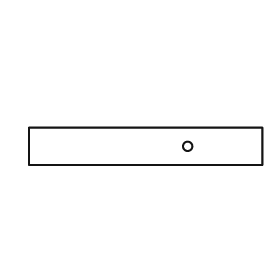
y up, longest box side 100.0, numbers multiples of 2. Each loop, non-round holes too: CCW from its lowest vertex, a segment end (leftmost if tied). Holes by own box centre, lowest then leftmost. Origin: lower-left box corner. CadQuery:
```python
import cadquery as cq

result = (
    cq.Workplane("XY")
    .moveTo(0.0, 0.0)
    .lineTo(100.0, 0.0)
    .lineTo(100.0, 16.0)
    .lineTo(0.0, 16.0)
    .close()
    .moveTo(68.0, 8.0)
    .circle(2.0)
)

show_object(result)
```